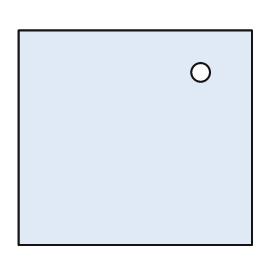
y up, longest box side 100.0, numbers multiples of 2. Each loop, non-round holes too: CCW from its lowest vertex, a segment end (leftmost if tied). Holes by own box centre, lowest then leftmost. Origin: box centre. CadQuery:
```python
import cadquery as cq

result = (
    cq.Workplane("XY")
    .moveTo(-50.0, -46.0)
    .lineTo(50.0, -46.0)
    .lineTo(50.0, 46.0)
    .lineTo(-50.0, 46.0)
    .close()
    .moveTo(28.0, 28.0)
    .circle(4.0)
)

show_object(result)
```